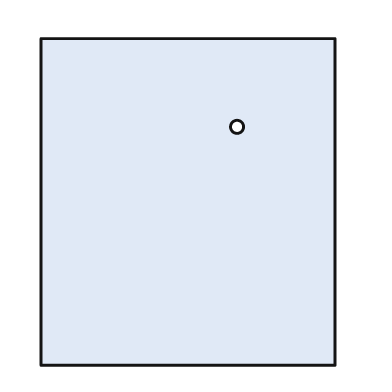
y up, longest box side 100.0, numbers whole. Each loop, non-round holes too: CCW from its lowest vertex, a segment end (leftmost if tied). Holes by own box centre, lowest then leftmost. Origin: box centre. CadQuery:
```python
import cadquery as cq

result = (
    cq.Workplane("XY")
    .moveTo(-45.0, -50.0)
    .lineTo(45.0, -50.0)
    .lineTo(45.0, 50.0)
    .lineTo(-45.0, 50.0)
    .close()
    .moveTo(15.0, 23.0)
    .circle(2.0)
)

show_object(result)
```